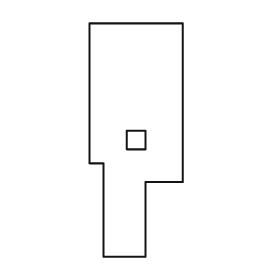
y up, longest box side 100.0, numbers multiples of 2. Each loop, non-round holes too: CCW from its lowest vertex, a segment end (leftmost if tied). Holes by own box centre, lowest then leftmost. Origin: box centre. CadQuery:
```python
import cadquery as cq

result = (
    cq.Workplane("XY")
    .moveTo(-14.0, -50.0)
    .lineTo(4.0, -50.0)
    .lineTo(4.0, -18.0)
    .lineTo(20.0, -18.0)
    .lineTo(20.0, 50.0)
    .lineTo(-20.0, 50.0)
    .lineTo(-20.0, -10.0)
    .lineTo(-14.0, -10.0)
    .close()
    .moveTo(-4.0, -4.0)
    .lineTo(4.0, -4.0)
    .lineTo(4.0, 4.0)
    .lineTo(-4.0, 4.0)
    .close()
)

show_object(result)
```